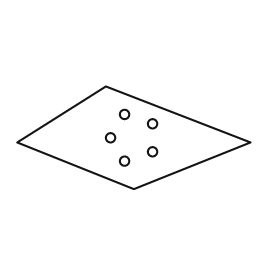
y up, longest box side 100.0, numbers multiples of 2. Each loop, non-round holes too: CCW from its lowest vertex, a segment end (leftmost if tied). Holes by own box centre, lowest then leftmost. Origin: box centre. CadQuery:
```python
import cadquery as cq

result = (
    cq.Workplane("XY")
    .moveTo(0.0, -22.0)
    .lineTo(50.0, -2.0)
    .lineTo(-12.0, 22.0)
    .lineTo(-50.0, -2.0)
    .close()
    .moveTo(-4.0, -10.0)
    .circle(2.0)
    .moveTo(8.0, -6.0)
    .circle(2.0)
    .moveTo(-10.0, 0.0)
    .circle(2.0)
    .moveTo(8.0, 6.0)
    .circle(2.0)
    .moveTo(-4.0, 10.0)
    .circle(2.0)
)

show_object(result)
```